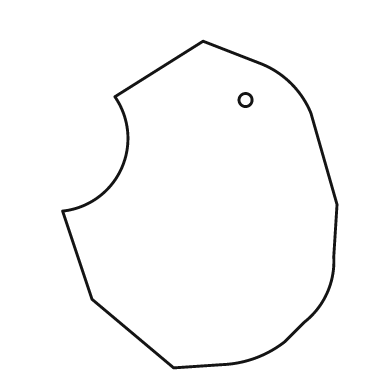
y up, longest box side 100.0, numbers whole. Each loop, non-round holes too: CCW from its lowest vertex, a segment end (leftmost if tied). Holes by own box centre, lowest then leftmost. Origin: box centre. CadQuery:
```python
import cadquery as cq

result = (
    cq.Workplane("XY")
    .moveTo(-8.0, -50.0)
    .lineTo(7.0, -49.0)
    .threePointArc((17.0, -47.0), (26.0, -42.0))
    .lineTo(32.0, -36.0)
    .threePointArc((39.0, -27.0), (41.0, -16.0))
    .lineTo(42.0, 0.0)
    .lineTo(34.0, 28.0)
    .threePointArc((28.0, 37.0), (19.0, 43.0))
    .lineTo(1.0, 50.0)
    .lineTo(-26.0, 33.0)
    .threePointArc((-24.0, 11.0), (-42.0, -2.0))
    .lineTo(-33.0, -29.0)
    .close()
    .moveTo(14.0, 32.0)
    .circle(2.0)
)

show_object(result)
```